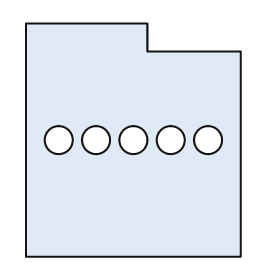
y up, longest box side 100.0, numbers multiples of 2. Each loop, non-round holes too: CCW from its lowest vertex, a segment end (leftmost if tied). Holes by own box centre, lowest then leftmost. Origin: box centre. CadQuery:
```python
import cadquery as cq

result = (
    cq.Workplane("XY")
    .moveTo(-46.0, -50.0)
    .lineTo(46.0, -50.0)
    .lineTo(46.0, 38.0)
    .lineTo(6.0, 38.0)
    .lineTo(6.0, 50.0)
    .lineTo(-46.0, 50.0)
    .close()
    .moveTo(-32.0, 0.0)
    .circle(6.0)
    .moveTo(-16.0, 0.0)
    .circle(6.0)
    .moveTo(0.0, 0.0)
    .circle(6.0)
    .moveTo(16.0, 0.0)
    .circle(6.0)
    .moveTo(32.0, 0.0)
    .circle(6.0)
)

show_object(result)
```